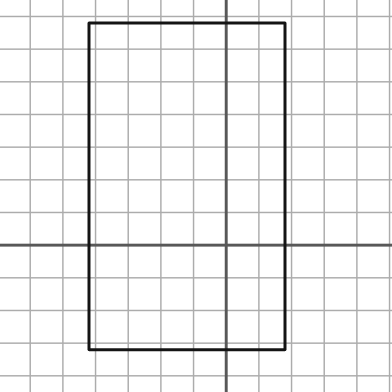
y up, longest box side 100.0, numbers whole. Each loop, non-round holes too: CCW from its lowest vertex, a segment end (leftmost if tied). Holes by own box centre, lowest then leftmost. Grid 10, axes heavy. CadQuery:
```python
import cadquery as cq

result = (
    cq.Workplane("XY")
    .moveTo(-42.0, -32.0)
    .lineTo(18.0, -32.0)
    .lineTo(18.0, 68.0)
    .lineTo(-42.0, 68.0)
    .close()
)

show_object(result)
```